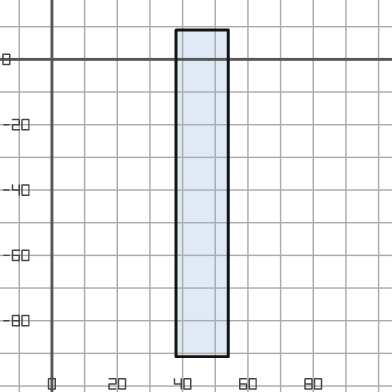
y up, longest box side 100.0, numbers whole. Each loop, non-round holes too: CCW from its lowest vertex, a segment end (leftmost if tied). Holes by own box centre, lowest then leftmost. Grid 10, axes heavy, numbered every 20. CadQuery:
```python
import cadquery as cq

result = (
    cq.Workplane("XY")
    .moveTo(38.0, -91.0)
    .lineTo(54.0, -91.0)
    .lineTo(54.0, 9.0)
    .lineTo(38.0, 9.0)
    .close()
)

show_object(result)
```